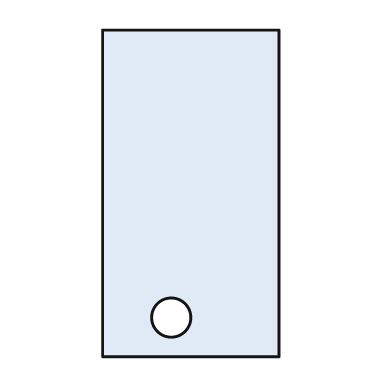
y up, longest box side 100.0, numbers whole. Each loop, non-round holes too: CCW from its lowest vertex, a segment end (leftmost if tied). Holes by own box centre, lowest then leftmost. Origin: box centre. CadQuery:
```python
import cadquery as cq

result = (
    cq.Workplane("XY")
    .moveTo(-27.0, -50.0)
    .lineTo(27.0, -50.0)
    .lineTo(27.0, 50.0)
    .lineTo(-27.0, 50.0)
    .close()
    .moveTo(-6.0, -38.0)
    .circle(6.0)
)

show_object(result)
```